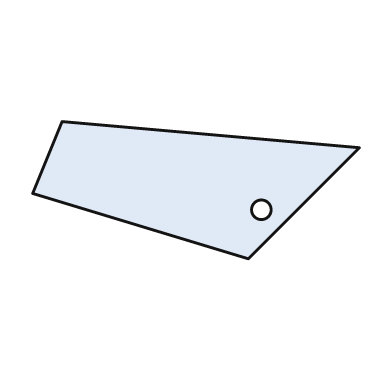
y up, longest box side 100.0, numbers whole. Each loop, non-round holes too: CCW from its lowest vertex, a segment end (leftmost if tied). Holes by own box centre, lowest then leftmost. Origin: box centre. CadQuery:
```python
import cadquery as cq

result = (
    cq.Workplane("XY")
    .moveTo(16.0, -21.0)
    .lineTo(50.0, 13.0)
    .lineTo(-41.0, 21.0)
    .lineTo(-50.0, -1.0)
    .close()
    .moveTo(20.0, -6.0)
    .circle(3.0)
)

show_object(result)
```